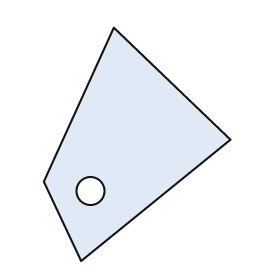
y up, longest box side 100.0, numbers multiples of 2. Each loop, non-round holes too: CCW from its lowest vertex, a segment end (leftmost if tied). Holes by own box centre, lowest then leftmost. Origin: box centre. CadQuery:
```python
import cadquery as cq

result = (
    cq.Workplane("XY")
    .moveTo(-24.0, -50.0)
    .lineTo(40.0, 2.0)
    .lineTo(-10.0, 50.0)
    .lineTo(-40.0, -16.0)
    .close()
    .moveTo(-20.0, -20.0)
    .circle(6.0)
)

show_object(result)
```